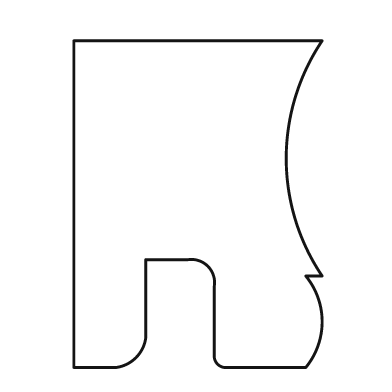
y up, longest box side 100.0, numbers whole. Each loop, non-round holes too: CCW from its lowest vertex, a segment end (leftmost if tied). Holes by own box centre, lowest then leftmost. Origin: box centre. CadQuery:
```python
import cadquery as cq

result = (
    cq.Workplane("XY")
    .moveTo(-38.0, -50.0)
    .lineTo(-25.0, -50.0)
    .threePointArc((-19.0, -47.0), (-16.0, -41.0))
    .lineTo(-16.0, -17.0)
    .lineTo(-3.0, -17.0)
    .threePointArc((3.0, -19.0), (5.0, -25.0))
    .lineTo(5.0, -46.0)
    .threePointArc((6.0, -49.0), (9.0, -50.0))
    .lineTo(33.0, -50.0)
    .threePointArc((38.0, -36.0), (33.0, -22.0))
    .lineTo(38.0, -22.0)
    .threePointArc((27.0, 14.0), (38.0, 50.0))
    .lineTo(-38.0, 50.0)
    .close()
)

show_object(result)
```